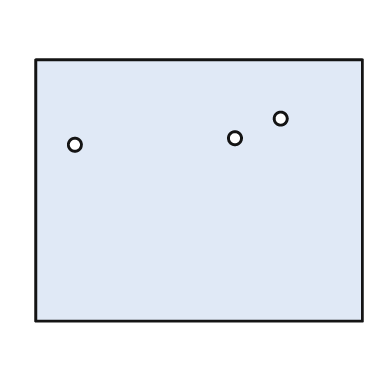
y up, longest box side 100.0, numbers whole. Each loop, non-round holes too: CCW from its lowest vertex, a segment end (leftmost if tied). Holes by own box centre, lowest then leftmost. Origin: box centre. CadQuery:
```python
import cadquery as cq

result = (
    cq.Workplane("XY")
    .moveTo(-50.0, -40.0)
    .lineTo(50.0, -40.0)
    .lineTo(50.0, 40.0)
    .lineTo(-50.0, 40.0)
    .close()
    .moveTo(-38.0, 14.0)
    .circle(2.0)
    .moveTo(11.0, 16.0)
    .circle(2.0)
    .moveTo(25.0, 22.0)
    .circle(2.0)
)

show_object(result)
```